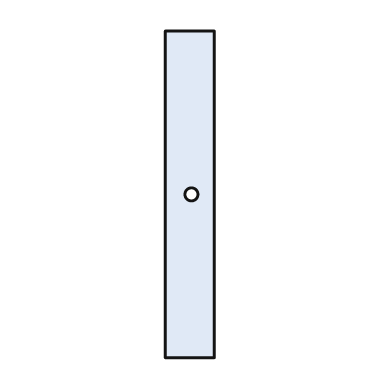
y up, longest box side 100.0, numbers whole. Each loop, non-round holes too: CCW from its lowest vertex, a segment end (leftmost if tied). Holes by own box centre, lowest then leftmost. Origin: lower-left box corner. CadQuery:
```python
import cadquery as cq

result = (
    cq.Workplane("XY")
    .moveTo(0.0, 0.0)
    .lineTo(15.0, 0.0)
    .lineTo(15.0, 100.0)
    .lineTo(0.0, 100.0)
    .close()
    .moveTo(8.0, 50.0)
    .circle(2.0)
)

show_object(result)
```